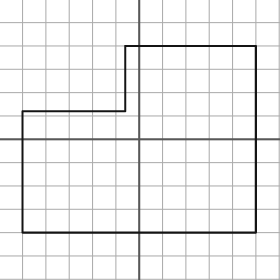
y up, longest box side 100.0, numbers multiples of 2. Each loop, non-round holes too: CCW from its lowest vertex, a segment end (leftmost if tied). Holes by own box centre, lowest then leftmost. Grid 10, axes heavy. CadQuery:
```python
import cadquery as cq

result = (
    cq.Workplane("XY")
    .moveTo(-50.0, -40.0)
    .lineTo(50.0, -40.0)
    .lineTo(50.0, 40.0)
    .lineTo(-6.0, 40.0)
    .lineTo(-6.0, 12.0)
    .lineTo(-50.0, 12.0)
    .close()
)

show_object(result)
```